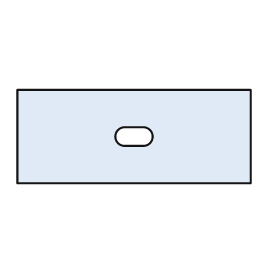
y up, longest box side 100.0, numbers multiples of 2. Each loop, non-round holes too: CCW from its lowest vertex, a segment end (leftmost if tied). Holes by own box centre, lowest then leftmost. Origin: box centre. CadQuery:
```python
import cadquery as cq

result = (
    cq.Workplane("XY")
    .moveTo(-50.0, -20.0)
    .lineTo(50.0, -20.0)
    .lineTo(50.0, 20.0)
    .lineTo(-50.0, 20.0)
    .close()
    .moveTo(-4.0, -4.0)
    .lineTo(4.0, -4.0)
    .threePointArc((8.0, 0.0), (4.0, 4.0))
    .lineTo(-4.0, 4.0)
    .threePointArc((-8.0, 0.0), (-4.0, -4.0))
    .close()
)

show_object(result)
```